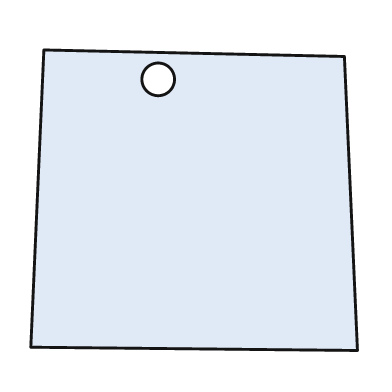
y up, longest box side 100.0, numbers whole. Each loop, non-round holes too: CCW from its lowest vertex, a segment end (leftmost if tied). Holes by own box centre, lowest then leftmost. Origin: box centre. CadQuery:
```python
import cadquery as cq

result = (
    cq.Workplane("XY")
    .moveTo(50.0, -46.0)
    .lineTo(46.0, 44.0)
    .lineTo(-46.0, 46.0)
    .lineTo(-50.0, -45.0)
    .close()
    .moveTo(-11.0, 37.0)
    .circle(5.0)
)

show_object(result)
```